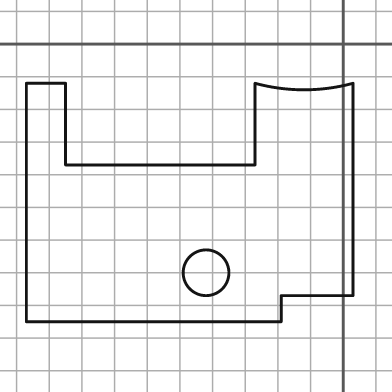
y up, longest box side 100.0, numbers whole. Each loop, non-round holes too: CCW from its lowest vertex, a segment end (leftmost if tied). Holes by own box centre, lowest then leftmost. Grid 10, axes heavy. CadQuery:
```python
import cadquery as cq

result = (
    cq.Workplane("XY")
    .moveTo(-97.0, -85.0)
    .lineTo(-19.0, -85.0)
    .lineTo(-19.0, -77.0)
    .lineTo(3.0, -77.0)
    .lineTo(3.0, -12.0)
    .threePointArc((-12.0, -14.0), (-27.0, -12.0))
    .lineTo(-27.0, -37.0)
    .lineTo(-85.0, -37.0)
    .lineTo(-85.0, -12.0)
    .lineTo(-97.0, -12.0)
    .close()
    .moveTo(-42.0, -70.0)
    .circle(7.0)
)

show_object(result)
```